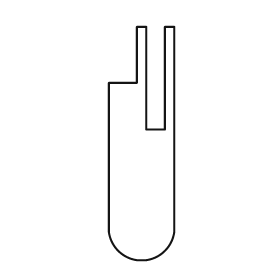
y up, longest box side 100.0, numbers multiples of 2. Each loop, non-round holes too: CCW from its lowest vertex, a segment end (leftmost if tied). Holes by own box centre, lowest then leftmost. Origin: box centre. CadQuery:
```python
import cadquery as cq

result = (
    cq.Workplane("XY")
    .moveTo(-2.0, -50.0)
    .lineTo(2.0, -50.0)
    .threePointArc((10.0, -46.0), (14.0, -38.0))
    .lineTo(14.0, 50.0)
    .lineTo(10.0, 50.0)
    .lineTo(10.0, 6.0)
    .lineTo(2.0, 6.0)
    .lineTo(2.0, 50.0)
    .lineTo(-2.0, 50.0)
    .lineTo(-2.0, 26.0)
    .lineTo(-14.0, 26.0)
    .lineTo(-14.0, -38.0)
    .threePointArc((-10.0, -46.0), (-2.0, -50.0))
    .close()
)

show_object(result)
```